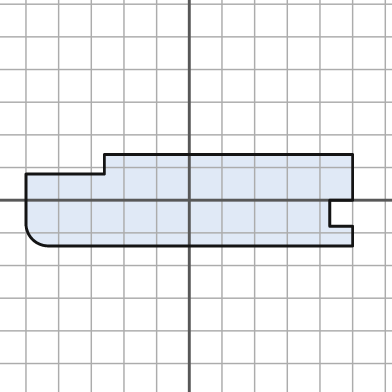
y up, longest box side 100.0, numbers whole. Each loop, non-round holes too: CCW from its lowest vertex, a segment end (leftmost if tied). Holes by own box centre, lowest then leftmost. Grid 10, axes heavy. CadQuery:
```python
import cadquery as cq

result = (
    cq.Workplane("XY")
    .moveTo(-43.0, -14.0)
    .lineTo(50.0, -14.0)
    .lineTo(50.0, -8.0)
    .lineTo(43.0, -8.0)
    .lineTo(43.0, 0.0)
    .lineTo(50.0, 0.0)
    .lineTo(50.0, 14.0)
    .lineTo(-26.0, 14.0)
    .lineTo(-26.0, 8.0)
    .lineTo(-50.0, 8.0)
    .lineTo(-50.0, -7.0)
    .threePointArc((-48.0, -12.0), (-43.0, -14.0))
    .close()
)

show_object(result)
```